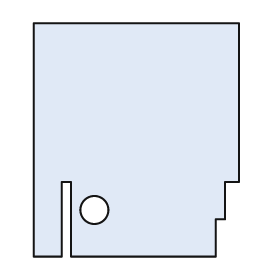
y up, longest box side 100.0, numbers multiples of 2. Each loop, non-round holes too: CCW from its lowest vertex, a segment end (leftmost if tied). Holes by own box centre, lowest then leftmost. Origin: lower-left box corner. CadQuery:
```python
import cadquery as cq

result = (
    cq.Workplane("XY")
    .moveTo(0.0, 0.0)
    .lineTo(12.0, 0.0)
    .lineTo(12.0, 32.0)
    .lineTo(16.0, 32.0)
    .lineTo(16.0, 0.0)
    .lineTo(78.0, 0.0)
    .lineTo(78.0, 16.0)
    .lineTo(82.0, 16.0)
    .lineTo(82.0, 32.0)
    .lineTo(88.0, 32.0)
    .lineTo(88.0, 100.0)
    .lineTo(0.0, 100.0)
    .close()
    .moveTo(26.0, 20.0)
    .circle(6.0)
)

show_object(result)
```